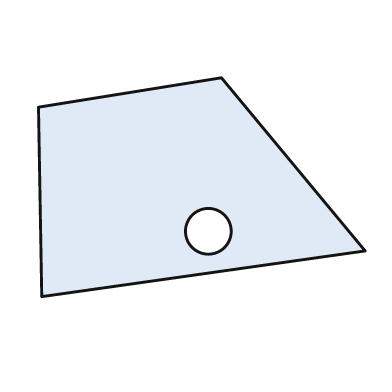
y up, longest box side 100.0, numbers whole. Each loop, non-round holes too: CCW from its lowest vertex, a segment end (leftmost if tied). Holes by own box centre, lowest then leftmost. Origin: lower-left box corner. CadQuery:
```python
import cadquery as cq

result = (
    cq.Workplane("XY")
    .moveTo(1.0, 0.0)
    .lineTo(100.0, 14.0)
    .lineTo(56.0, 67.0)
    .lineTo(0.0, 58.0)
    .close()
    .moveTo(52.0, 20.0)
    .circle(7.0)
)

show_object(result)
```